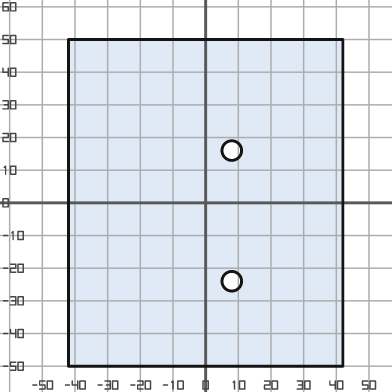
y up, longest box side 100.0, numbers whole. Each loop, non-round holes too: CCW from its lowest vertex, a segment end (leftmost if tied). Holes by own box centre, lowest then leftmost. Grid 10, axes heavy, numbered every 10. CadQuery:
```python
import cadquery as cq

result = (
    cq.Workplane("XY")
    .moveTo(-42.0, -50.0)
    .lineTo(42.0, -50.0)
    .lineTo(42.0, 50.0)
    .lineTo(-42.0, 50.0)
    .close()
    .moveTo(8.0, -24.0)
    .circle(3.0)
    .moveTo(8.0, 16.0)
    .circle(3.0)
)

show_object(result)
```